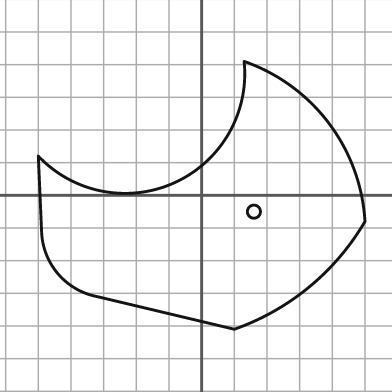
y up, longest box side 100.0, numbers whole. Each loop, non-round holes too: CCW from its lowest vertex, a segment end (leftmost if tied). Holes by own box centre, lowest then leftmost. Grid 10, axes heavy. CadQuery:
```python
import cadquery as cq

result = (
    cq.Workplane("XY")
    .moveTo(10.0, -41.0)
    .threePointArc((33.0, -28.0), (50.0, -8.0))
    .threePointArc((39.0, 22.0), (13.0, 41.0))
    .threePointArc((-8.0, 4.0), (-50.0, 12.0))
    .lineTo(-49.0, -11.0)
    .threePointArc((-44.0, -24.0), (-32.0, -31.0))
    .close()
    .moveTo(16.0, -5.0)
    .circle(2.0)
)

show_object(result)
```